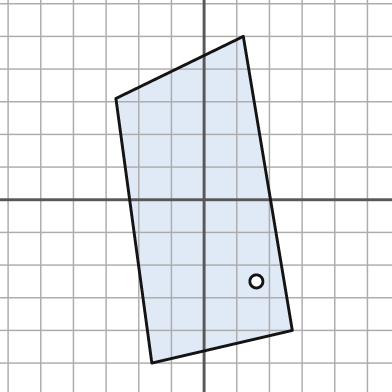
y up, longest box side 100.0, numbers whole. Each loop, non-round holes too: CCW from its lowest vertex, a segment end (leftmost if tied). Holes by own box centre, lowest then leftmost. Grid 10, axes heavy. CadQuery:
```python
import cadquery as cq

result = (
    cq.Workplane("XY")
    .moveTo(-16.0, -50.0)
    .lineTo(27.0, -40.0)
    .lineTo(12.0, 50.0)
    .lineTo(-27.0, 31.0)
    .close()
    .moveTo(16.0, -25.0)
    .circle(2.0)
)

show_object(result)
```